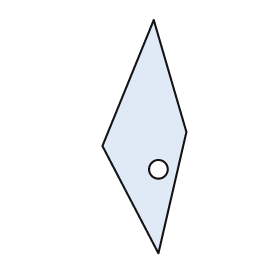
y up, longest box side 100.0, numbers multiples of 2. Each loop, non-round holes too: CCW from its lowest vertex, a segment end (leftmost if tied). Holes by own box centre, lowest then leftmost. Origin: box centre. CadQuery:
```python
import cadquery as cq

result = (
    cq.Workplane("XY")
    .moveTo(6.0, -50.0)
    .lineTo(18.0, 2.0)
    .lineTo(4.0, 50.0)
    .lineTo(-18.0, -4.0)
    .close()
    .moveTo(6.0, -14.0)
    .circle(4.0)
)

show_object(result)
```